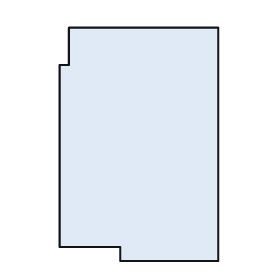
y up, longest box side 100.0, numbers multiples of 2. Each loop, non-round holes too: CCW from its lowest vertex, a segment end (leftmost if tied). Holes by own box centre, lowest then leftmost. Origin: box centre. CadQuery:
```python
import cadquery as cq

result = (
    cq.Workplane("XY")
    .moveTo(-8.0, -50.0)
    .lineTo(34.0, -50.0)
    .lineTo(34.0, 50.0)
    .lineTo(-30.0, 50.0)
    .lineTo(-30.0, 34.0)
    .lineTo(-34.0, 34.0)
    .lineTo(-34.0, -44.0)
    .lineTo(-8.0, -44.0)
    .close()
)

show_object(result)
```